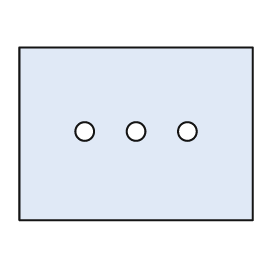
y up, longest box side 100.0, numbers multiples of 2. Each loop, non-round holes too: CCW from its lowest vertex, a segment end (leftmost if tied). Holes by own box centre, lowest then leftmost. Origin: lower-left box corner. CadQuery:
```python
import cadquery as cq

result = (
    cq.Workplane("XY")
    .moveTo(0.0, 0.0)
    .lineTo(100.0, 0.0)
    .lineTo(100.0, 74.0)
    .lineTo(0.0, 74.0)
    .close()
    .moveTo(28.0, 38.0)
    .circle(4.0)
    .moveTo(50.0, 38.0)
    .circle(4.0)
    .moveTo(72.0, 38.0)
    .circle(4.0)
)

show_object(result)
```